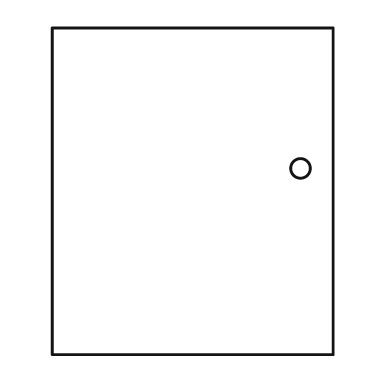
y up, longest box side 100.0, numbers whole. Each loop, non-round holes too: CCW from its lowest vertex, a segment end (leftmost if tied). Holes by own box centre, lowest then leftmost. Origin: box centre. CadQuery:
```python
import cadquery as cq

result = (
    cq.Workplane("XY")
    .moveTo(-43.0, -50.0)
    .lineTo(43.0, -50.0)
    .lineTo(43.0, 50.0)
    .lineTo(-43.0, 50.0)
    .close()
    .moveTo(33.0, 7.0)
    .circle(3.0)
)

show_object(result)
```